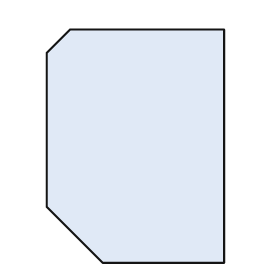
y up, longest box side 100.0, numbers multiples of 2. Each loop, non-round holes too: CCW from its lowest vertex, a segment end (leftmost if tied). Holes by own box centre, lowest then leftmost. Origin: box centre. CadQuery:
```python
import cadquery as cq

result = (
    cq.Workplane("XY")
    .moveTo(-14.0, -50.0)
    .lineTo(38.0, -50.0)
    .lineTo(38.0, 50.0)
    .lineTo(-28.0, 50.0)
    .lineTo(-38.0, 40.0)
    .lineTo(-38.0, -26.0)
    .close()
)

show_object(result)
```